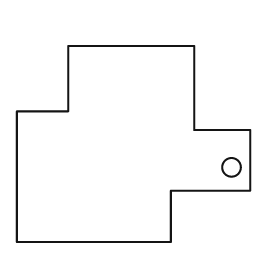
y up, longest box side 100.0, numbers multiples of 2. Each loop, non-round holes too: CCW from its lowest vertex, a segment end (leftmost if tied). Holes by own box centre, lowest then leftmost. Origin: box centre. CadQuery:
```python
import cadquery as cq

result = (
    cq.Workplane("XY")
    .moveTo(-50.0, -42.0)
    .lineTo(16.0, -42.0)
    .lineTo(16.0, -20.0)
    .lineTo(50.0, -20.0)
    .lineTo(50.0, 6.0)
    .lineTo(26.0, 6.0)
    .lineTo(26.0, 42.0)
    .lineTo(-28.0, 42.0)
    .lineTo(-28.0, 14.0)
    .lineTo(-50.0, 14.0)
    .close()
    .moveTo(42.0, -10.0)
    .circle(4.0)
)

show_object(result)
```